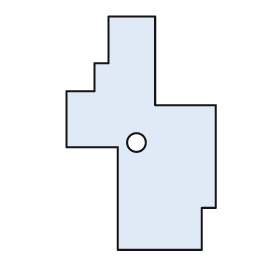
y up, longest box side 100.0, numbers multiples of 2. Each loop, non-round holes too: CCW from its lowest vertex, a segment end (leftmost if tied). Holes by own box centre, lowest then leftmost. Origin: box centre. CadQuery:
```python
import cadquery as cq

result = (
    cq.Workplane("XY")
    .moveTo(-10.0, -50.0)
    .lineTo(26.0, -50.0)
    .lineTo(26.0, -32.0)
    .lineTo(32.0, -32.0)
    .lineTo(32.0, 12.0)
    .lineTo(6.0, 12.0)
    .lineTo(6.0, 50.0)
    .lineTo(-14.0, 50.0)
    .lineTo(-14.0, 30.0)
    .lineTo(-20.0, 30.0)
    .lineTo(-20.0, 18.0)
    .lineTo(-32.0, 18.0)
    .lineTo(-32.0, -6.0)
    .lineTo(-10.0, -6.0)
    .close()
    .moveTo(-2.0, -4.0)
    .circle(4.0)
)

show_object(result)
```